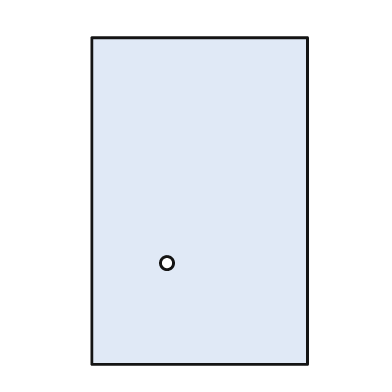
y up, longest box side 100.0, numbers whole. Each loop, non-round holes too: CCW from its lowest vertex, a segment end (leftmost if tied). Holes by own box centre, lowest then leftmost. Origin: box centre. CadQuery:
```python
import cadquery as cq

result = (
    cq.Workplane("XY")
    .moveTo(-33.0, -50.0)
    .lineTo(33.0, -50.0)
    .lineTo(33.0, 50.0)
    .lineTo(-33.0, 50.0)
    .close()
    .moveTo(-10.0, -19.0)
    .circle(2.0)
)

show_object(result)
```